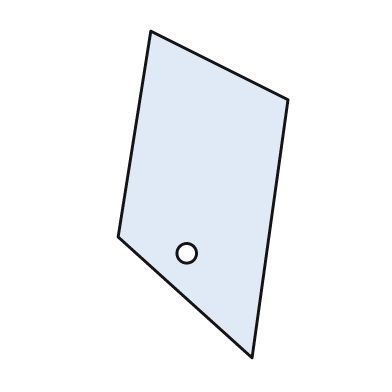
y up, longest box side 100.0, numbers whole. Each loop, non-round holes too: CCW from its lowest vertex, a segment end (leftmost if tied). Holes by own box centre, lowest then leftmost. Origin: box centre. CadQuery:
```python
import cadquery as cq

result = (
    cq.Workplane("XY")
    .moveTo(15.0, -50.0)
    .lineTo(26.0, 29.0)
    .lineTo(-16.0, 50.0)
    .lineTo(-26.0, -13.0)
    .close()
    .moveTo(-5.0, -18.0)
    .circle(3.0)
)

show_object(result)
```